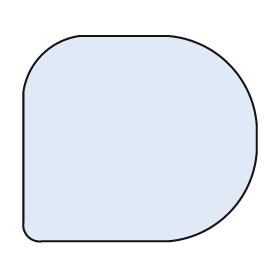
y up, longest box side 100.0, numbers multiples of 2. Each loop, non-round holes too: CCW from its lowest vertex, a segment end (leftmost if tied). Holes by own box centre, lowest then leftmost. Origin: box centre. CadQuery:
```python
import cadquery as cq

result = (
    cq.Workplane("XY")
    .moveTo(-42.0, -44.0)
    .lineTo(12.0, -44.0)
    .threePointArc((38.0, -32.0), (50.0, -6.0))
    .lineTo(50.0, 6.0)
    .threePointArc((38.0, 32.0), (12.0, 44.0))
    .lineTo(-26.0, 44.0)
    .threePointArc((-42.0, 36.0), (-50.0, 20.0))
    .lineTo(-50.0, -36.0)
    .threePointArc((-48.0, -42.0), (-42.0, -44.0))
    .close()
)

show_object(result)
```